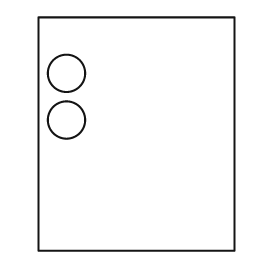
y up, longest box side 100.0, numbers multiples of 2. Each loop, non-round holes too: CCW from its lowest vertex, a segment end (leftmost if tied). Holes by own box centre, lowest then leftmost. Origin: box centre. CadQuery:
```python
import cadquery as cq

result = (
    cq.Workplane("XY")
    .moveTo(-42.0, -50.0)
    .lineTo(42.0, -50.0)
    .lineTo(42.0, 50.0)
    .lineTo(-42.0, 50.0)
    .close()
    .moveTo(-30.0, 6.0)
    .circle(8.0)
    .moveTo(-30.0, 26.0)
    .circle(8.0)
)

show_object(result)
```